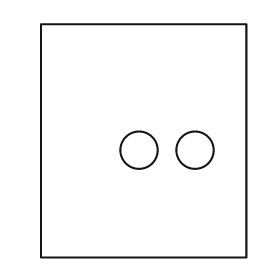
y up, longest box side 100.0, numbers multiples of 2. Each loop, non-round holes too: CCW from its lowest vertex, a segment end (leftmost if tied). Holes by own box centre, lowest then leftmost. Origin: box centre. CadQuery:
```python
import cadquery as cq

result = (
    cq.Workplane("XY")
    .moveTo(-44.0, -50.0)
    .lineTo(44.0, -50.0)
    .lineTo(44.0, 50.0)
    .lineTo(-44.0, 50.0)
    .close()
    .moveTo(-2.0, -4.0)
    .circle(8.0)
    .moveTo(22.0, -4.0)
    .circle(8.0)
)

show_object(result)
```